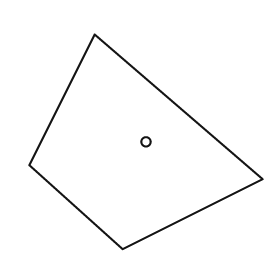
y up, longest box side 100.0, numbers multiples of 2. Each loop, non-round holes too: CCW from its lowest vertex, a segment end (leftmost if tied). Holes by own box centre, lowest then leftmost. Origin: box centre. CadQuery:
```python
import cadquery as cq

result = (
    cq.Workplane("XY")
    .moveTo(-10.0, -46.0)
    .lineTo(50.0, -16.0)
    .lineTo(-22.0, 46.0)
    .lineTo(-50.0, -10.0)
    .close()
    .moveTo(0.0, 0.0)
    .circle(2.0)
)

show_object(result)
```